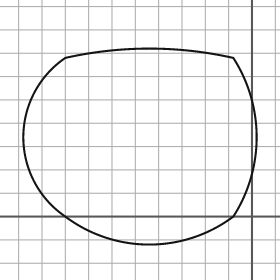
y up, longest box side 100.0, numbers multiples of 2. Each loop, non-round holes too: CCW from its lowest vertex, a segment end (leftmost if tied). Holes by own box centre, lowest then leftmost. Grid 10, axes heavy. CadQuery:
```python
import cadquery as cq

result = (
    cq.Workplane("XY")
    .moveTo(-80.0, 0.0)
    .threePointArc((-44.0, -12.0), (-8.0, 0.0))
    .threePointArc((2.0, 34.0), (-8.0, 68.0))
    .threePointArc((-44.0, 72.0), (-80.0, 68.0))
    .threePointArc((-98.0, 34.0), (-80.0, 0.0))
    .close()
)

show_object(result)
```